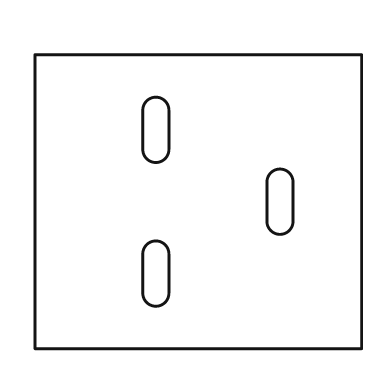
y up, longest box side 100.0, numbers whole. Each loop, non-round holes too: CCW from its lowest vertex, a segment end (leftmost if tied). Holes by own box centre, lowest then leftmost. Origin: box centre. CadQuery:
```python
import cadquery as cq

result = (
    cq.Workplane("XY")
    .moveTo(-50.0, -45.0)
    .lineTo(50.0, -45.0)
    .lineTo(50.0, 45.0)
    .lineTo(-50.0, 45.0)
    .close()
    .moveTo(-17.0, -28.0)
    .threePointArc((-13.0, -32.0), (-9.0, -28.0))
    .lineTo(-9.0, -16.0)
    .threePointArc((-13.0, -12.0), (-17.0, -16.0))
    .close()
    .moveTo(21.0, -6.0)
    .threePointArc((25.0, -10.0), (29.0, -6.0))
    .lineTo(29.0, 6.0)
    .threePointArc((25.0, 10.0), (21.0, 6.0))
    .close()
    .moveTo(-17.0, 16.0)
    .threePointArc((-13.0, 12.0), (-9.0, 16.0))
    .lineTo(-9.0, 28.0)
    .threePointArc((-13.0, 32.0), (-17.0, 28.0))
    .close()
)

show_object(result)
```